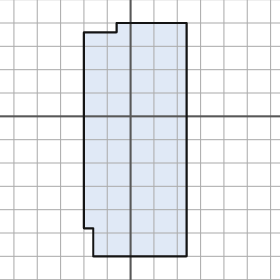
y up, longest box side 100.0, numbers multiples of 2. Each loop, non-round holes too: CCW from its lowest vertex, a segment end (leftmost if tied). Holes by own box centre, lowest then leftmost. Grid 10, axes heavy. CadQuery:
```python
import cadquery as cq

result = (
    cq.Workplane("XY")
    .moveTo(-16.0, -60.0)
    .lineTo(24.0, -60.0)
    .lineTo(24.0, 40.0)
    .lineTo(-6.0, 40.0)
    .lineTo(-6.0, 36.0)
    .lineTo(-20.0, 36.0)
    .lineTo(-20.0, -48.0)
    .lineTo(-16.0, -48.0)
    .close()
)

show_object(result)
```